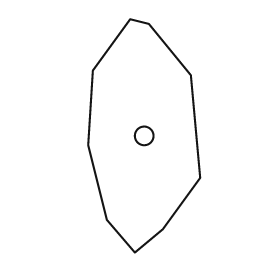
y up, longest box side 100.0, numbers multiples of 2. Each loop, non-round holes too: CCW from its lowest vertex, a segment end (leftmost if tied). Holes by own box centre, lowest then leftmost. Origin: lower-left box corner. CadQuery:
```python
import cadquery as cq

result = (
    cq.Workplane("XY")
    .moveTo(20.0, 0.0)
    .lineTo(32.0, 10.0)
    .lineTo(48.0, 32.0)
    .lineTo(44.0, 76.0)
    .lineTo(26.0, 98.0)
    .lineTo(18.0, 100.0)
    .lineTo(2.0, 78.0)
    .lineTo(0.0, 46.0)
    .lineTo(8.0, 14.0)
    .close()
    .moveTo(24.0, 50.0)
    .circle(4.0)
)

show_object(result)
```